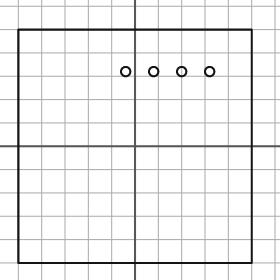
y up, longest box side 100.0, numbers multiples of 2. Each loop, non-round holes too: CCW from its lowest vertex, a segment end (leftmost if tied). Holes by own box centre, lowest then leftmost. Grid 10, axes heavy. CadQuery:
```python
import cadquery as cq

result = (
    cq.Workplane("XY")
    .moveTo(-50.0, -50.0)
    .lineTo(50.0, -50.0)
    .lineTo(50.0, 50.0)
    .lineTo(-50.0, 50.0)
    .close()
    .moveTo(-4.0, 32.0)
    .circle(2.0)
    .moveTo(8.0, 32.0)
    .circle(2.0)
    .moveTo(20.0, 32.0)
    .circle(2.0)
    .moveTo(32.0, 32.0)
    .circle(2.0)
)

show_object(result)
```